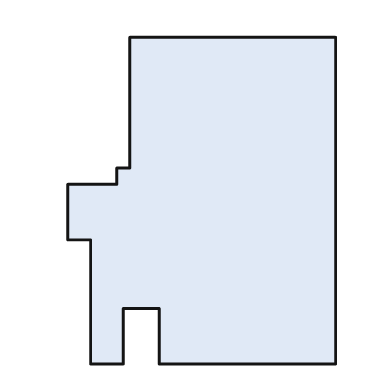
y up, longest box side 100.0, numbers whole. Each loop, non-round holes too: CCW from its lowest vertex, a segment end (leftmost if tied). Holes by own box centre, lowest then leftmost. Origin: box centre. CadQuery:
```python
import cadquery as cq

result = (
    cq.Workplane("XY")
    .moveTo(-34.0, -50.0)
    .lineTo(-24.0, -50.0)
    .lineTo(-24.0, -33.0)
    .lineTo(-13.0, -33.0)
    .lineTo(-13.0, -50.0)
    .lineTo(41.0, -50.0)
    .lineTo(41.0, 50.0)
    .lineTo(-22.0, 50.0)
    .lineTo(-22.0, 10.0)
    .lineTo(-26.0, 10.0)
    .lineTo(-26.0, 5.0)
    .lineTo(-41.0, 5.0)
    .lineTo(-41.0, -12.0)
    .lineTo(-34.0, -12.0)
    .close()
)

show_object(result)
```